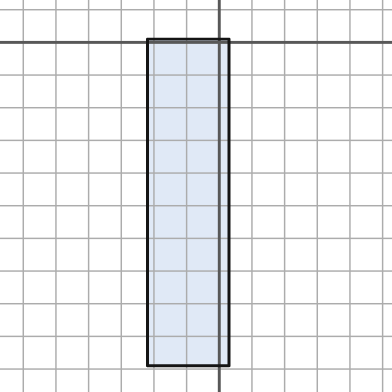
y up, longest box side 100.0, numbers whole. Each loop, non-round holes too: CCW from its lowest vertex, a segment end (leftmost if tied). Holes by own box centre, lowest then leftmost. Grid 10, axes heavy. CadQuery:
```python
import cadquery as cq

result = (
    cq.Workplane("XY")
    .moveTo(-22.0, -99.0)
    .lineTo(3.0, -99.0)
    .lineTo(3.0, 1.0)
    .lineTo(-22.0, 1.0)
    .close()
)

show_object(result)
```